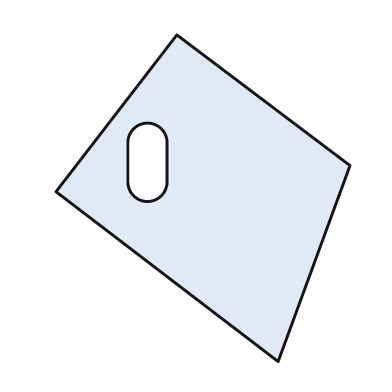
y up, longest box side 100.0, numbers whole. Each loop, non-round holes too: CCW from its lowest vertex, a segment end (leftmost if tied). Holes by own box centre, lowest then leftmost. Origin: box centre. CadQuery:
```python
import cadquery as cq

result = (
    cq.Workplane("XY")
    .moveTo(23.0, -50.0)
    .lineTo(45.0, 10.0)
    .lineTo(-8.0, 50.0)
    .lineTo(-45.0, 2.0)
    .close()
    .moveTo(-23.0, 5.0)
    .threePointArc((-17.0, -1.0), (-11.0, 5.0))
    .lineTo(-11.0, 17.0)
    .threePointArc((-17.0, 23.0), (-23.0, 17.0))
    .close()
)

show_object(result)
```